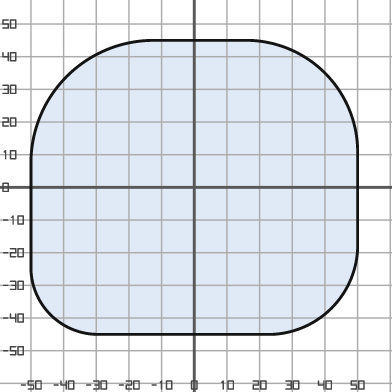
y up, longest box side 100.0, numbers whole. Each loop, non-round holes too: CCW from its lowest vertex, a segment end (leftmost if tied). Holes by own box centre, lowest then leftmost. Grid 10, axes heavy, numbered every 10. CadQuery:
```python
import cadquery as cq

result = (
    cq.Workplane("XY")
    .moveTo(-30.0, -45.0)
    .lineTo(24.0, -45.0)
    .threePointArc((42.0, -37.0), (50.0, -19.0))
    .lineTo(50.0, 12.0)
    .threePointArc((40.0, 35.0), (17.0, 45.0))
    .lineTo(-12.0, 45.0)
    .threePointArc((-39.0, 34.0), (-50.0, 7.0))
    .lineTo(-50.0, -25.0)
    .threePointArc((-44.0, -39.0), (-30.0, -45.0))
    .close()
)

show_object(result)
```